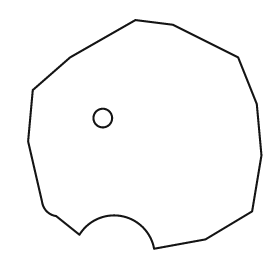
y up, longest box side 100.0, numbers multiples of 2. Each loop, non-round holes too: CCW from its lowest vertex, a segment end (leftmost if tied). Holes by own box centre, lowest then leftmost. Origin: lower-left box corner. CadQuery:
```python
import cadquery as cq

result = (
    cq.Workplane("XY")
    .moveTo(54.0, 0.0)
    .lineTo(76.0, 4.0)
    .lineTo(96.0, 16.0)
    .lineTo(100.0, 40.0)
    .lineTo(98.0, 62.0)
    .lineTo(90.0, 82.0)
    .lineTo(62.0, 96.0)
    .lineTo(46.0, 98.0)
    .lineTo(18.0, 82.0)
    .lineTo(2.0, 68.0)
    .lineTo(0.0, 46.0)
    .lineTo(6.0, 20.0)
    .threePointArc((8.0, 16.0), (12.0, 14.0))
    .lineTo(22.0, 6.0)
    .threePointArc((40.0, 14.0), (54.0, 0.0))
    .close()
    .moveTo(32.0, 56.0)
    .circle(4.0)
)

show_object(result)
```